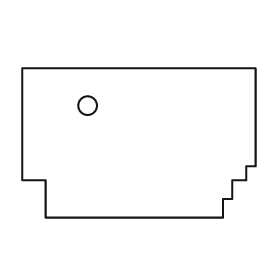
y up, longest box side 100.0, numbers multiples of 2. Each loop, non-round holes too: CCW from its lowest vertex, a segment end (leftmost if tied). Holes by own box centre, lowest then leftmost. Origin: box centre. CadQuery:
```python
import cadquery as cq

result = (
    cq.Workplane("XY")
    .moveTo(-40.0, -32.0)
    .lineTo(36.0, -32.0)
    .lineTo(36.0, -24.0)
    .lineTo(40.0, -24.0)
    .lineTo(40.0, -16.0)
    .lineTo(46.0, -16.0)
    .lineTo(46.0, -10.0)
    .lineTo(50.0, -10.0)
    .lineTo(50.0, 32.0)
    .lineTo(-50.0, 32.0)
    .lineTo(-50.0, -16.0)
    .lineTo(-40.0, -16.0)
    .close()
    .moveTo(-22.0, 16.0)
    .circle(4.0)
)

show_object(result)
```